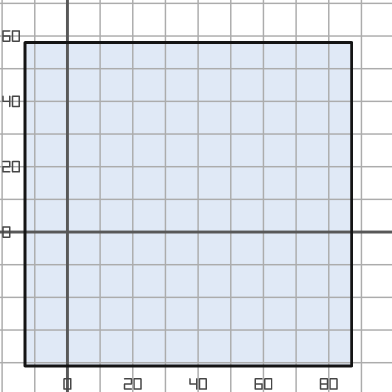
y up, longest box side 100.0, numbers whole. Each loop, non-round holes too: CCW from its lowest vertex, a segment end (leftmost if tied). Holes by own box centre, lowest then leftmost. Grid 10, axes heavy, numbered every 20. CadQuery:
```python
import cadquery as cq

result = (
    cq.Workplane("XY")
    .moveTo(-13.0, -41.0)
    .lineTo(87.0, -41.0)
    .lineTo(87.0, 58.0)
    .lineTo(-13.0, 58.0)
    .close()
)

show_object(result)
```